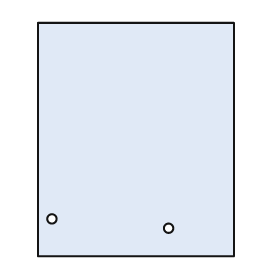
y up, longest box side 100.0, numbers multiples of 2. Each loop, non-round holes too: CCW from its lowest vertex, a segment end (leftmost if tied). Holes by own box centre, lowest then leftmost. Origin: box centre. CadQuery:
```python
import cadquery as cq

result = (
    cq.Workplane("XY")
    .moveTo(-42.0, -50.0)
    .lineTo(42.0, -50.0)
    .lineTo(42.0, 50.0)
    .lineTo(-42.0, 50.0)
    .close()
    .moveTo(14.0, -38.0)
    .circle(2.0)
    .moveTo(-36.0, -34.0)
    .circle(2.0)
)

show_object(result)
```